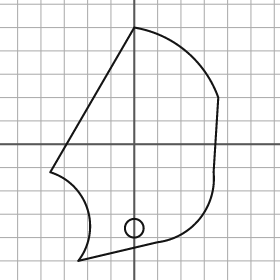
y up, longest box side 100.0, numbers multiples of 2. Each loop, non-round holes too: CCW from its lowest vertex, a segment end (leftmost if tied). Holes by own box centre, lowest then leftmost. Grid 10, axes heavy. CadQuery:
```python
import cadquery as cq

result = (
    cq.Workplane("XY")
    .moveTo(-24.0, -50.0)
    .lineTo(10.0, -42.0)
    .threePointArc((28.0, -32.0), (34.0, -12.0))
    .lineTo(36.0, 20.0)
    .threePointArc((22.0, 40.0), (0.0, 50.0))
    .lineTo(-36.0, -12.0)
    .threePointArc((-20.0, -28.0), (-24.0, -50.0))
    .close()
    .moveTo(0.0, -36.0)
    .circle(4.0)
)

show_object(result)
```